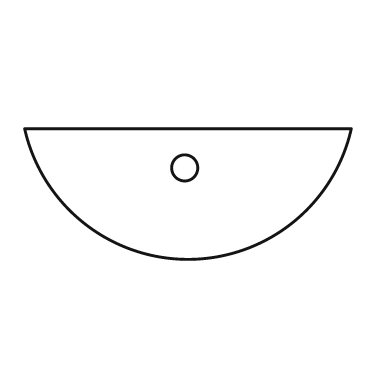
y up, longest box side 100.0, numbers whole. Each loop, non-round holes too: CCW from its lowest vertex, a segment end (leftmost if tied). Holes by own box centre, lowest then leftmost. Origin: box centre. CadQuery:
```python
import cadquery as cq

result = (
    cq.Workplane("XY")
    .moveTo(-50.0, 20.0)
    .threePointArc((0.0, -20.0), (50.0, 20.0))
    .close()
    .moveTo(-1.0, 8.0)
    .circle(4.0)
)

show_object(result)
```